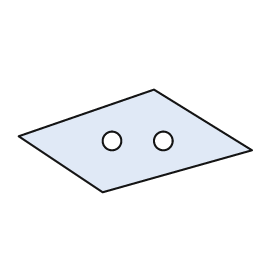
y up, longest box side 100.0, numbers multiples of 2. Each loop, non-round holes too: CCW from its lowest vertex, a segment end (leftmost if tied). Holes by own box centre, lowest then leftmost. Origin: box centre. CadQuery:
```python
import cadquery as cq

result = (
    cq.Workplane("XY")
    .moveTo(-14.0, -22.0)
    .lineTo(50.0, -4.0)
    .lineTo(8.0, 22.0)
    .lineTo(-50.0, 2.0)
    .close()
    .moveTo(-10.0, 0.0)
    .circle(4.0)
    .moveTo(12.0, 0.0)
    .circle(4.0)
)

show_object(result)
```